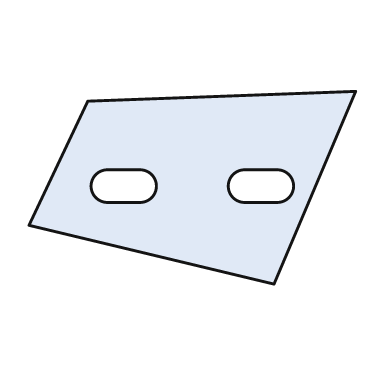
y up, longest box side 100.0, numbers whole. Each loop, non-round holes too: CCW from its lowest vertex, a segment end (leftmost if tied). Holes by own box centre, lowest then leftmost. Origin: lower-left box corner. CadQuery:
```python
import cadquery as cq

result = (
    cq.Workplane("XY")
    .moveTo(75.0, 0.0)
    .lineTo(100.0, 59.0)
    .lineTo(18.0, 56.0)
    .lineTo(0.0, 18.0)
    .close()
    .moveTo(24.0, 25.0)
    .lineTo(34.0, 25.0)
    .threePointArc((39.0, 30.0), (34.0, 35.0))
    .lineTo(24.0, 35.0)
    .threePointArc((19.0, 30.0), (24.0, 25.0))
    .close()
    .moveTo(66.0, 25.0)
    .lineTo(76.0, 25.0)
    .threePointArc((81.0, 30.0), (76.0, 35.0))
    .lineTo(66.0, 35.0)
    .threePointArc((61.0, 30.0), (66.0, 25.0))
    .close()
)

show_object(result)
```